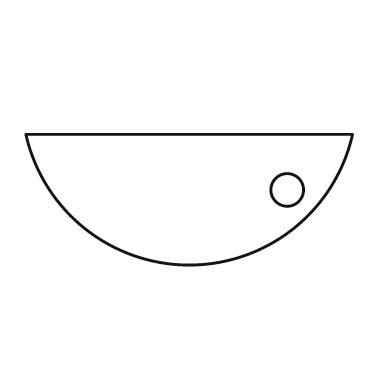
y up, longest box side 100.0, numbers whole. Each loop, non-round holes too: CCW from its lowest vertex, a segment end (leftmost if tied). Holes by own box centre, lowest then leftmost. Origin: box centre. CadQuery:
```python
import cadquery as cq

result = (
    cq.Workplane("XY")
    .moveTo(-50.0, 20.0)
    .threePointArc((0.0, -20.0), (50.0, 20.0))
    .close()
    .moveTo(30.0, 3.0)
    .circle(5.0)
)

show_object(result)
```